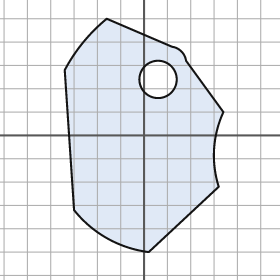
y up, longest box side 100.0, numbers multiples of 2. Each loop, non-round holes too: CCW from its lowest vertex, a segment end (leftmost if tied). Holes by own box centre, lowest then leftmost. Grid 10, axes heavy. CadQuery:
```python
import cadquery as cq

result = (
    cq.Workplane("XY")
    .moveTo(2.0, -50.0)
    .lineTo(32.0, -22.0)
    .threePointArc((30.0, -6.0), (34.0, 10.0))
    .lineTo(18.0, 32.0)
    .threePointArc((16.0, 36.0), (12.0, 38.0))
    .lineTo(-16.0, 50.0)
    .threePointArc((-26.0, 40.0), (-34.0, 28.0))
    .lineTo(-30.0, -32.0)
    .threePointArc((-16.0, -44.0), (2.0, -50.0))
    .close()
    .moveTo(6.0, 24.0)
    .circle(8.0)
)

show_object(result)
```